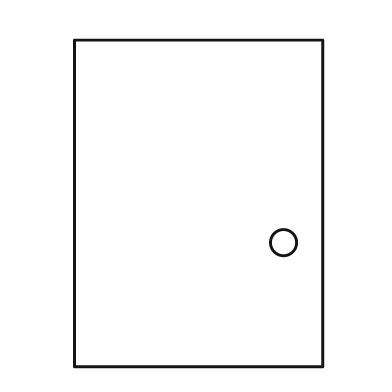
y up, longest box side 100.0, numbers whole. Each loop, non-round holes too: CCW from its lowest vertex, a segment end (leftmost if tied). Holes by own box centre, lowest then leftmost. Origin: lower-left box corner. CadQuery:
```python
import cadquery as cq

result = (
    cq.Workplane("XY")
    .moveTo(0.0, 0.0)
    .lineTo(76.0, 0.0)
    .lineTo(76.0, 100.0)
    .lineTo(0.0, 100.0)
    .close()
    .moveTo(64.0, 38.0)
    .circle(4.0)
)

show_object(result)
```